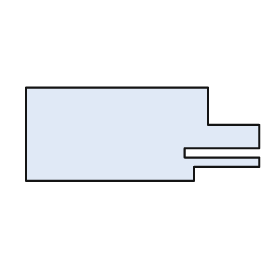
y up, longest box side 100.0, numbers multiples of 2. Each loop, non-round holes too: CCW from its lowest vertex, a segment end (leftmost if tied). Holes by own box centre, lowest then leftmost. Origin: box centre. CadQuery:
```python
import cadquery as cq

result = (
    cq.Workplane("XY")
    .moveTo(-50.0, -20.0)
    .lineTo(22.0, -20.0)
    .lineTo(22.0, -14.0)
    .lineTo(50.0, -14.0)
    .lineTo(50.0, -10.0)
    .lineTo(18.0, -10.0)
    .lineTo(18.0, -6.0)
    .lineTo(50.0, -6.0)
    .lineTo(50.0, 4.0)
    .lineTo(28.0, 4.0)
    .lineTo(28.0, 20.0)
    .lineTo(-50.0, 20.0)
    .close()
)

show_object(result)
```